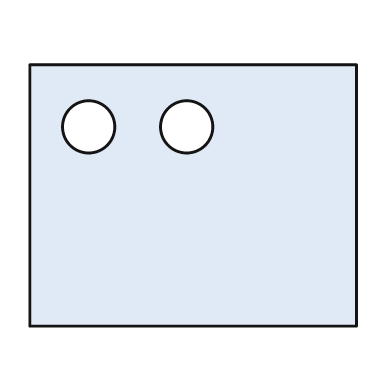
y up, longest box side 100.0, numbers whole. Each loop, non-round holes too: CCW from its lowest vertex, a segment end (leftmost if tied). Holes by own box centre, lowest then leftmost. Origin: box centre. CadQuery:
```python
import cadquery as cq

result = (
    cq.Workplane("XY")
    .moveTo(-50.0, -40.0)
    .lineTo(50.0, -40.0)
    .lineTo(50.0, 40.0)
    .lineTo(-50.0, 40.0)
    .close()
    .moveTo(-32.0, 21.0)
    .circle(8.0)
    .moveTo(-2.0, 21.0)
    .circle(8.0)
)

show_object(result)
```